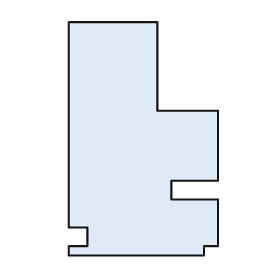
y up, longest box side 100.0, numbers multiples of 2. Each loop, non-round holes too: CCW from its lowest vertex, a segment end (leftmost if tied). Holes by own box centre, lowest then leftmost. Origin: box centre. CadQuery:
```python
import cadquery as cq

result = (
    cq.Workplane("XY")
    .moveTo(-32.0, -50.0)
    .lineTo(26.0, -50.0)
    .lineTo(26.0, -46.0)
    .lineTo(32.0, -46.0)
    .lineTo(32.0, -26.0)
    .lineTo(12.0, -26.0)
    .lineTo(12.0, -18.0)
    .lineTo(32.0, -18.0)
    .lineTo(32.0, 12.0)
    .lineTo(6.0, 12.0)
    .lineTo(6.0, 50.0)
    .lineTo(-32.0, 50.0)
    .lineTo(-32.0, -38.0)
    .lineTo(-24.0, -38.0)
    .lineTo(-24.0, -46.0)
    .lineTo(-32.0, -46.0)
    .close()
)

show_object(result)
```